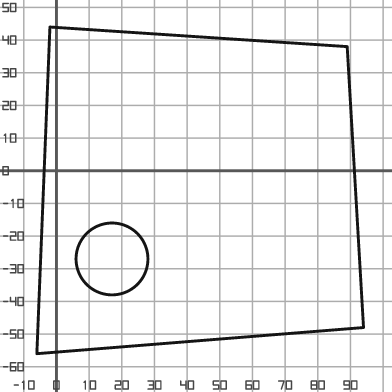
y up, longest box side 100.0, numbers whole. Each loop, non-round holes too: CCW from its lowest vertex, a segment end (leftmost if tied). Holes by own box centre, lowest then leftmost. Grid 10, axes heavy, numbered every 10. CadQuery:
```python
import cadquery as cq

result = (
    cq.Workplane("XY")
    .moveTo(-6.0, -56.0)
    .lineTo(94.0, -48.0)
    .lineTo(89.0, 38.0)
    .lineTo(-2.0, 44.0)
    .close()
    .moveTo(17.0, -27.0)
    .circle(11.0)
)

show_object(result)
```